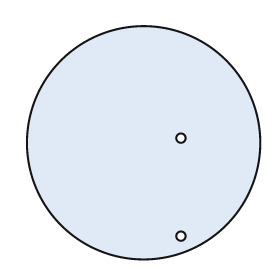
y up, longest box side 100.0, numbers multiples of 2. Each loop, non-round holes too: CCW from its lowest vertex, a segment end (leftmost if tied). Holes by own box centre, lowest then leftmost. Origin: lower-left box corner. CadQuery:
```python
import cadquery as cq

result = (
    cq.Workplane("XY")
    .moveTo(50.0, 50.0)
    .circle(50.0)
    .moveTo(66.0, 10.0)
    .circle(2.0)
    .moveTo(66.0, 52.0)
    .circle(2.0)
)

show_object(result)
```